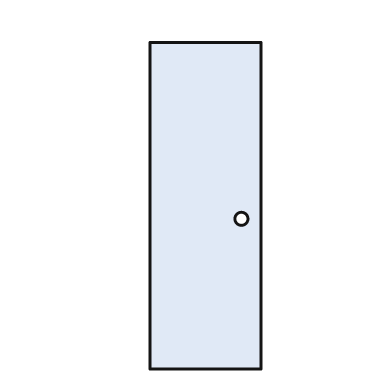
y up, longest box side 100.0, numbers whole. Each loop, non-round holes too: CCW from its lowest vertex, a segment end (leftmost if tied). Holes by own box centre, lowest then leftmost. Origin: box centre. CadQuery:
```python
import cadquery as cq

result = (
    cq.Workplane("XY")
    .moveTo(-17.0, -50.0)
    .lineTo(17.0, -50.0)
    .lineTo(17.0, 50.0)
    .lineTo(-17.0, 50.0)
    .close()
    .moveTo(11.0, -4.0)
    .circle(2.0)
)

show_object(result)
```